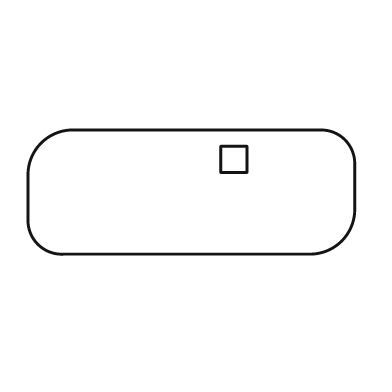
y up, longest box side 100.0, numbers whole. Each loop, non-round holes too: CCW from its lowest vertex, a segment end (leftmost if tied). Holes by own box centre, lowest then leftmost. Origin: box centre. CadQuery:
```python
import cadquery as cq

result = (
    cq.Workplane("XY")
    .moveTo(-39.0, -19.0)
    .lineTo(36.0, -19.0)
    .threePointArc((46.0, -15.0), (50.0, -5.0))
    .lineTo(50.0, 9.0)
    .threePointArc((47.0, 16.0), (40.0, 19.0))
    .lineTo(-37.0, 19.0)
    .threePointArc((-46.0, 15.0), (-50.0, 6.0))
    .lineTo(-50.0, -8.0)
    .threePointArc((-47.0, -16.0), (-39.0, -19.0))
    .close()
    .moveTo(9.0, 6.0)
    .lineTo(17.0, 6.0)
    .lineTo(17.0, 14.0)
    .lineTo(9.0, 14.0)
    .close()
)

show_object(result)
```